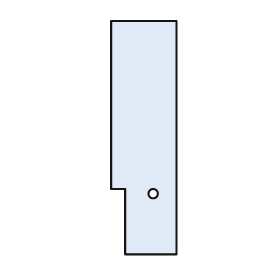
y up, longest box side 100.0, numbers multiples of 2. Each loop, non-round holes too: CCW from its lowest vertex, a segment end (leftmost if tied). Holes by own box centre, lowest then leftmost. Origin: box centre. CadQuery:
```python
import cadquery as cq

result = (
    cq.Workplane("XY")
    .moveTo(-8.0, -50.0)
    .lineTo(14.0, -50.0)
    .lineTo(14.0, 50.0)
    .lineTo(-14.0, 50.0)
    .lineTo(-14.0, -22.0)
    .lineTo(-8.0, -22.0)
    .close()
    .moveTo(4.0, -24.0)
    .circle(2.0)
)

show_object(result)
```